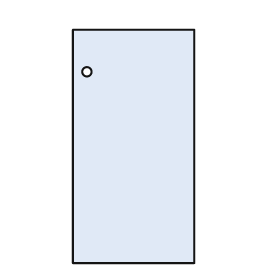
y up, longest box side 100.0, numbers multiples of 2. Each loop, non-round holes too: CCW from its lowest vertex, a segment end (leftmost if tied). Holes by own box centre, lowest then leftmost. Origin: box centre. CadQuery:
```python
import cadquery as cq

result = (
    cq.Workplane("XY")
    .moveTo(-26.0, -50.0)
    .lineTo(26.0, -50.0)
    .lineTo(26.0, 50.0)
    .lineTo(-26.0, 50.0)
    .close()
    .moveTo(-20.0, 32.0)
    .circle(2.0)
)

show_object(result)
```